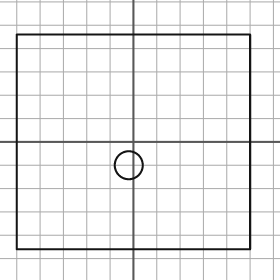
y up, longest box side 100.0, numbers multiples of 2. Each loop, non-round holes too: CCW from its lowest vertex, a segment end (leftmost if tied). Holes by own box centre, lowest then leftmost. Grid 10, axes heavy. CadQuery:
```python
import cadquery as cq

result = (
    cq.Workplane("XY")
    .moveTo(-50.0, -46.0)
    .lineTo(50.0, -46.0)
    .lineTo(50.0, 46.0)
    .lineTo(-50.0, 46.0)
    .close()
    .moveTo(-2.0, -10.0)
    .circle(6.0)
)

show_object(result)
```